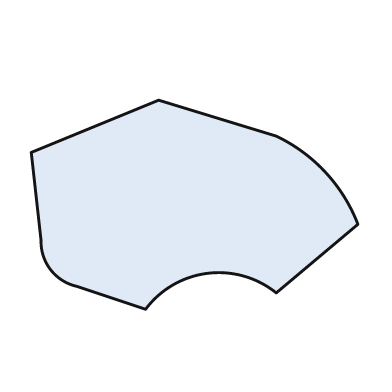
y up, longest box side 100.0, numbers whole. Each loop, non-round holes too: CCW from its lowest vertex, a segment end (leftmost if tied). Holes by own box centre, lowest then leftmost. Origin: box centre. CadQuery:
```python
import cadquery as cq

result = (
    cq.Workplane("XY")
    .moveTo(-15.0, -32.0)
    .threePointArc((4.0, -21.0), (25.0, -27.0))
    .lineTo(50.0, -6.0)
    .threePointArc((40.0, 10.0), (25.0, 21.0))
    .lineTo(-11.0, 32.0)
    .lineTo(-50.0, 16.0)
    .lineTo(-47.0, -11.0)
    .threePointArc((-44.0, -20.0), (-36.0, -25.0))
    .close()
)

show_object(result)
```